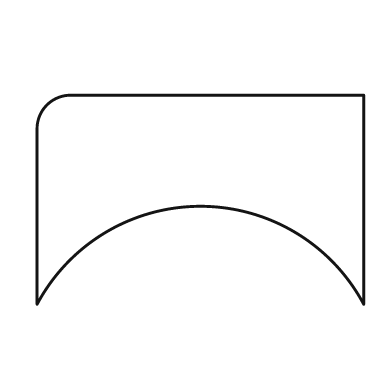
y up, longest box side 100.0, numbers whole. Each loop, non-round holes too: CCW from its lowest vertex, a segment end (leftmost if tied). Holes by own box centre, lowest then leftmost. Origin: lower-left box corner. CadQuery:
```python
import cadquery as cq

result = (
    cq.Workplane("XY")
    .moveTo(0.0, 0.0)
    .threePointArc((50.0, 30.0), (100.0, 0.0))
    .lineTo(100.0, 64.0)
    .lineTo(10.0, 64.0)
    .threePointArc((3.0, 61.0), (0.0, 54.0))
    .close()
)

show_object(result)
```